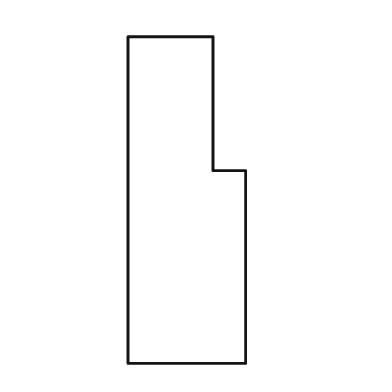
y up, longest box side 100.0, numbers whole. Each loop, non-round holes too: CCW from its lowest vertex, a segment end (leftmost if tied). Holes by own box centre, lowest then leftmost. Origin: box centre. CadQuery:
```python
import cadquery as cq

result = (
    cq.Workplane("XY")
    .moveTo(-18.0, -50.0)
    .lineTo(18.0, -50.0)
    .lineTo(18.0, 9.0)
    .lineTo(8.0, 9.0)
    .lineTo(8.0, 50.0)
    .lineTo(-18.0, 50.0)
    .close()
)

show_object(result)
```